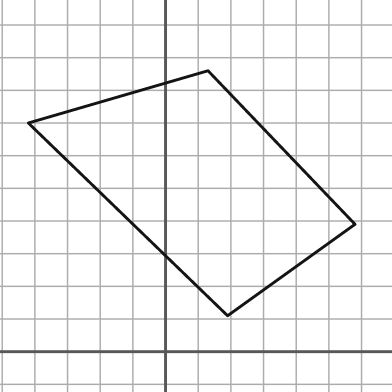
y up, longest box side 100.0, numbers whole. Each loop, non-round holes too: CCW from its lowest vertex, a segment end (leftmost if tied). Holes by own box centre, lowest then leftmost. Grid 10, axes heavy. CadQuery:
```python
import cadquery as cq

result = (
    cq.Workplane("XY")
    .moveTo(19.0, 11.0)
    .lineTo(58.0, 39.0)
    .lineTo(13.0, 86.0)
    .lineTo(-42.0, 70.0)
    .close()
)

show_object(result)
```